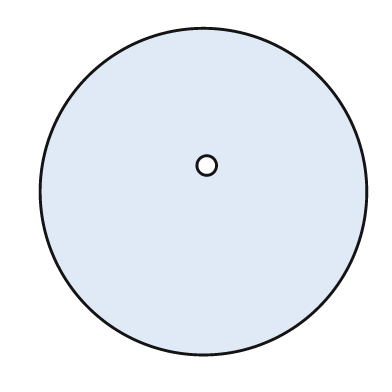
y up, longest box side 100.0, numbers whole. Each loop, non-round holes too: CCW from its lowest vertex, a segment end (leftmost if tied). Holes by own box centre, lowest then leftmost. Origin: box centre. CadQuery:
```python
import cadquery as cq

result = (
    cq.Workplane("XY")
    .moveTo(0.0, 0.0)
    .circle(50.0)
    .moveTo(1.0, 8.0)
    .circle(3.0)
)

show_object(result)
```